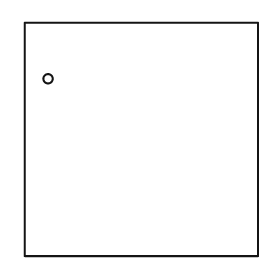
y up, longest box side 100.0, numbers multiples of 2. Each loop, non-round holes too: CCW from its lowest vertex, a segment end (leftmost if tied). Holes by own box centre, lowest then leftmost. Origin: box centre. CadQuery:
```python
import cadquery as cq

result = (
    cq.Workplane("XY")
    .moveTo(-50.0, -50.0)
    .lineTo(50.0, -50.0)
    .lineTo(50.0, 50.0)
    .lineTo(-50.0, 50.0)
    .close()
    .moveTo(-40.0, 26.0)
    .circle(2.0)
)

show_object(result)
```